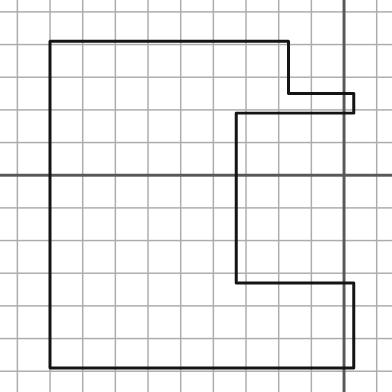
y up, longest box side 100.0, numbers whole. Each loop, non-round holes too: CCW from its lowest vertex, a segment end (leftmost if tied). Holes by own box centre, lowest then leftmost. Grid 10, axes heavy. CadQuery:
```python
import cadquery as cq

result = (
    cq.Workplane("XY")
    .moveTo(-90.0, -59.0)
    .lineTo(3.0, -59.0)
    .lineTo(3.0, -33.0)
    .lineTo(-33.0, -33.0)
    .lineTo(-33.0, 19.0)
    .lineTo(3.0, 19.0)
    .lineTo(3.0, 25.0)
    .lineTo(-17.0, 25.0)
    .lineTo(-17.0, 41.0)
    .lineTo(-90.0, 41.0)
    .close()
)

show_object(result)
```